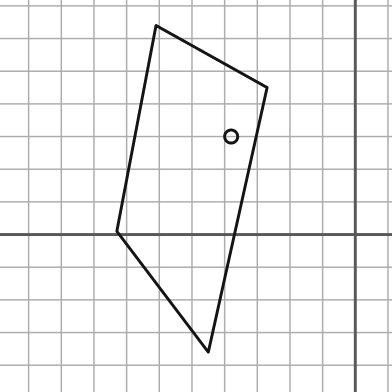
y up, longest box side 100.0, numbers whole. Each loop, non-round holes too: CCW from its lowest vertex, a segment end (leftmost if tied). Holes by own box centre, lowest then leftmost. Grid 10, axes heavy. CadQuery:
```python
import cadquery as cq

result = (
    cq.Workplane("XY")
    .moveTo(-45.0, -36.0)
    .lineTo(-27.0, 45.0)
    .lineTo(-61.0, 64.0)
    .lineTo(-73.0, 1.0)
    .close()
    .moveTo(-38.0, 30.0)
    .circle(2.0)
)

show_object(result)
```